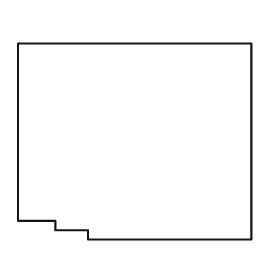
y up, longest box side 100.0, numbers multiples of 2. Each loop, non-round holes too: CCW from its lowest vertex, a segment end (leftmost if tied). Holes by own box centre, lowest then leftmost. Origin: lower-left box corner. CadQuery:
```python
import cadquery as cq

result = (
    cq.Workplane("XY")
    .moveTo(30.0, 0.0)
    .lineTo(100.0, 0.0)
    .lineTo(100.0, 84.0)
    .lineTo(0.0, 84.0)
    .lineTo(0.0, 8.0)
    .lineTo(16.0, 8.0)
    .lineTo(16.0, 4.0)
    .lineTo(30.0, 4.0)
    .close()
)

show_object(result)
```